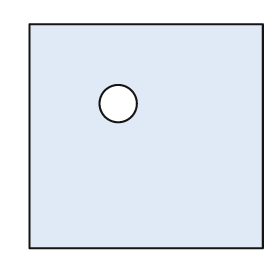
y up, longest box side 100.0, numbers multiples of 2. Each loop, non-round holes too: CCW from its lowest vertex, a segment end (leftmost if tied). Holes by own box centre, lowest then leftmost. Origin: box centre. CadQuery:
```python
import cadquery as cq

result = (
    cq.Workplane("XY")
    .moveTo(-50.0, -48.0)
    .lineTo(50.0, -48.0)
    .lineTo(50.0, 48.0)
    .lineTo(-50.0, 48.0)
    .close()
    .moveTo(-12.0, 14.0)
    .circle(8.0)
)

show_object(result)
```